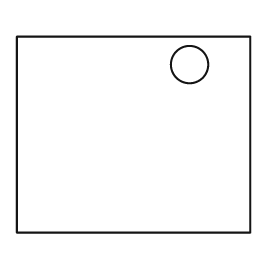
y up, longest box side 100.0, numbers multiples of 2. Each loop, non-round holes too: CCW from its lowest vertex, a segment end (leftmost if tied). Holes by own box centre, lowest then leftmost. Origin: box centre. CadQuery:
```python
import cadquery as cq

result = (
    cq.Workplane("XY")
    .moveTo(-50.0, -42.0)
    .lineTo(50.0, -42.0)
    .lineTo(50.0, 42.0)
    .lineTo(-50.0, 42.0)
    .close()
    .moveTo(24.0, 30.0)
    .circle(8.0)
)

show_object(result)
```